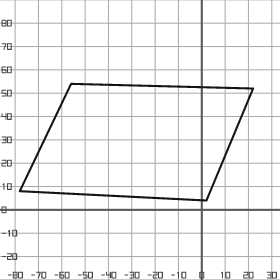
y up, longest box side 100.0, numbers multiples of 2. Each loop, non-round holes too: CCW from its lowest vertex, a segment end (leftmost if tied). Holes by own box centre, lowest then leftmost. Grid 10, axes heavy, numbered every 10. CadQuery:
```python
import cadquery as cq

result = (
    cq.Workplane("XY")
    .moveTo(2.0, 4.0)
    .lineTo(22.0, 52.0)
    .lineTo(-56.0, 54.0)
    .lineTo(-78.0, 8.0)
    .close()
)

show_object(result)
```